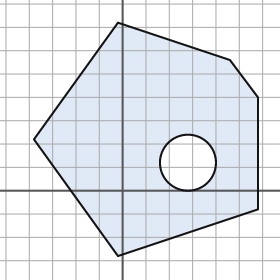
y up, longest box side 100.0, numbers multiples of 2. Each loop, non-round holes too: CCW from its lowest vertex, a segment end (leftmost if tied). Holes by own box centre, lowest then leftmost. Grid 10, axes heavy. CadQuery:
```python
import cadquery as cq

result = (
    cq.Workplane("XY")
    .moveTo(-2.0, -28.0)
    .lineTo(58.0, -8.0)
    .lineTo(58.0, 40.0)
    .lineTo(46.0, 56.0)
    .lineTo(-2.0, 72.0)
    .lineTo(-38.0, 22.0)
    .close()
    .moveTo(28.0, 12.0)
    .circle(12.0)
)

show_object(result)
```